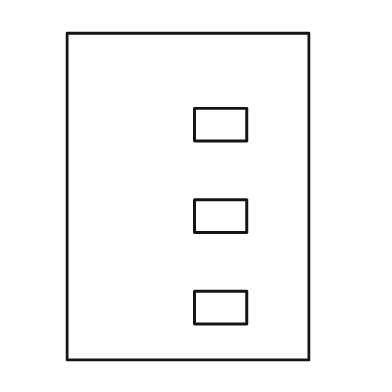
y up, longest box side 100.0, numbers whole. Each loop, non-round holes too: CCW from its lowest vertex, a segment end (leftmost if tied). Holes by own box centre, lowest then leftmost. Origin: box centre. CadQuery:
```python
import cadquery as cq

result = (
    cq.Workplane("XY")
    .moveTo(-37.0, -50.0)
    .lineTo(37.0, -50.0)
    .lineTo(37.0, 50.0)
    .lineTo(-37.0, 50.0)
    .close()
    .moveTo(2.0, -39.0)
    .lineTo(18.0, -39.0)
    .lineTo(18.0, -29.0)
    .lineTo(2.0, -29.0)
    .close()
    .moveTo(2.0, -11.0)
    .lineTo(18.0, -11.0)
    .lineTo(18.0, -1.0)
    .lineTo(2.0, -1.0)
    .close()
    .moveTo(2.0, 17.0)
    .lineTo(18.0, 17.0)
    .lineTo(18.0, 27.0)
    .lineTo(2.0, 27.0)
    .close()
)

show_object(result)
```